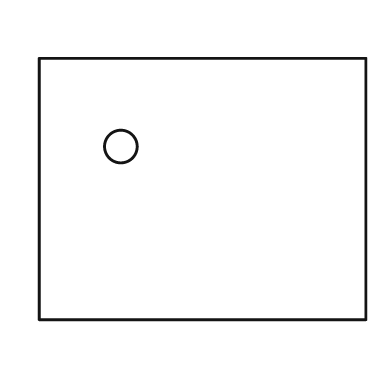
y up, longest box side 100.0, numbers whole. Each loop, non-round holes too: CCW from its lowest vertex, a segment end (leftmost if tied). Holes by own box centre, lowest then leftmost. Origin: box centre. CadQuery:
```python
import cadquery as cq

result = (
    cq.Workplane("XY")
    .moveTo(-50.0, -40.0)
    .lineTo(50.0, -40.0)
    .lineTo(50.0, 40.0)
    .lineTo(-50.0, 40.0)
    .close()
    .moveTo(-25.0, 13.0)
    .circle(5.0)
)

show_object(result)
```